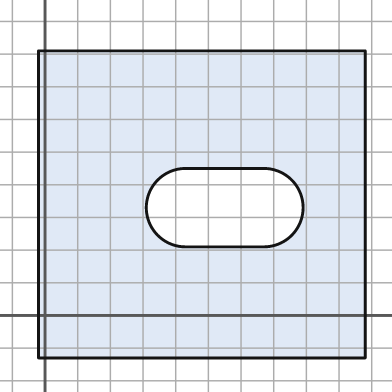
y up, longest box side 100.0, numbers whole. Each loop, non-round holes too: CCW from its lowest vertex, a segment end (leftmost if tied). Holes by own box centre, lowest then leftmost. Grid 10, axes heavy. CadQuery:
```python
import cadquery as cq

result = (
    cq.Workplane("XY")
    .moveTo(-2.0, -13.0)
    .lineTo(98.0, -13.0)
    .lineTo(98.0, 81.0)
    .lineTo(-2.0, 81.0)
    .close()
    .moveTo(43.0, 21.0)
    .lineTo(67.0, 21.0)
    .threePointArc((79.0, 33.0), (67.0, 45.0))
    .lineTo(43.0, 45.0)
    .threePointArc((31.0, 33.0), (43.0, 21.0))
    .close()
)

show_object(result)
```